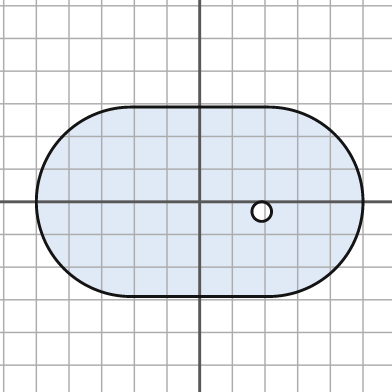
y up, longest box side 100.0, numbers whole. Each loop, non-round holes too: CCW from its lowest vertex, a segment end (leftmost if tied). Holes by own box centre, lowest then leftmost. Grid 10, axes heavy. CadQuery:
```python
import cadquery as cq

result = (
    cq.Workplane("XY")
    .moveTo(-21.0, -29.0)
    .lineTo(21.0, -29.0)
    .threePointArc((50.0, 0.0), (21.0, 29.0))
    .lineTo(-21.0, 29.0)
    .threePointArc((-50.0, 0.0), (-21.0, -29.0))
    .close()
    .moveTo(19.0, -3.0)
    .circle(3.0)
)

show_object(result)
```